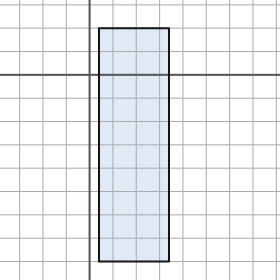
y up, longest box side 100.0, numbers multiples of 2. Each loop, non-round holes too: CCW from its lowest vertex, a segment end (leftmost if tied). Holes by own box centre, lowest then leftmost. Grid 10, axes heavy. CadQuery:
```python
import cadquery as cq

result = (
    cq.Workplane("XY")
    .moveTo(4.0, -80.0)
    .lineTo(34.0, -80.0)
    .lineTo(34.0, 20.0)
    .lineTo(4.0, 20.0)
    .close()
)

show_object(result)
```